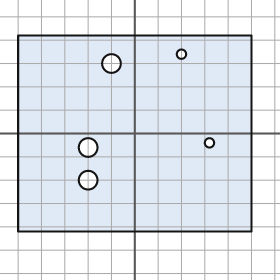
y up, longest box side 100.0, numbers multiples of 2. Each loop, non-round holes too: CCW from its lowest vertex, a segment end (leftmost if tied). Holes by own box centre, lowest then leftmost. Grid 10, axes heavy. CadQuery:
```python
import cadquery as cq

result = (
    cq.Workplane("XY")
    .moveTo(-50.0, -42.0)
    .lineTo(50.0, -42.0)
    .lineTo(50.0, 42.0)
    .lineTo(-50.0, 42.0)
    .close()
    .moveTo(-20.0, -20.0)
    .circle(4.0)
    .moveTo(-20.0, -6.0)
    .circle(4.0)
    .moveTo(32.0, -4.0)
    .circle(2.0)
    .moveTo(-10.0, 30.0)
    .circle(4.0)
    .moveTo(20.0, 34.0)
    .circle(2.0)
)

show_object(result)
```